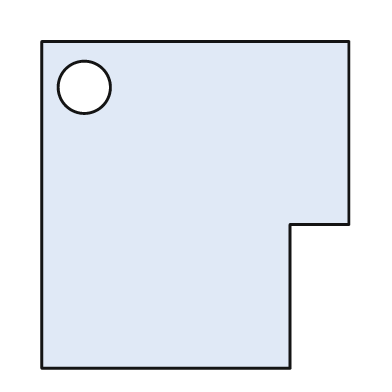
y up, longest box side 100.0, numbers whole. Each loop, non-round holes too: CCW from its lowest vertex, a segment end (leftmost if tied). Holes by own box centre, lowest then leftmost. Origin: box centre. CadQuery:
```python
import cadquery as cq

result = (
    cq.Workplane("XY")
    .moveTo(-47.0, -50.0)
    .lineTo(29.0, -50.0)
    .lineTo(29.0, -6.0)
    .lineTo(47.0, -6.0)
    .lineTo(47.0, 50.0)
    .lineTo(-47.0, 50.0)
    .close()
    .moveTo(-34.0, 36.0)
    .circle(8.0)
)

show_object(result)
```